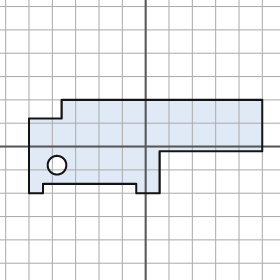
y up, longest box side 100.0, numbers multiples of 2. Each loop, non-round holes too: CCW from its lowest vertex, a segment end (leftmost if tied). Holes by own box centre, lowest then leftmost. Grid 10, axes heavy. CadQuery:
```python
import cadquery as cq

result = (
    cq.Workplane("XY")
    .moveTo(-50.0, -20.0)
    .lineTo(-44.0, -20.0)
    .lineTo(-44.0, -16.0)
    .lineTo(-4.0, -16.0)
    .lineTo(-4.0, -20.0)
    .lineTo(6.0, -20.0)
    .lineTo(6.0, -2.0)
    .lineTo(50.0, -2.0)
    .lineTo(50.0, 20.0)
    .lineTo(-36.0, 20.0)
    .lineTo(-36.0, 12.0)
    .lineTo(-50.0, 12.0)
    .close()
    .moveTo(-38.0, -8.0)
    .circle(4.0)
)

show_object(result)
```